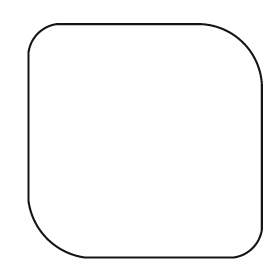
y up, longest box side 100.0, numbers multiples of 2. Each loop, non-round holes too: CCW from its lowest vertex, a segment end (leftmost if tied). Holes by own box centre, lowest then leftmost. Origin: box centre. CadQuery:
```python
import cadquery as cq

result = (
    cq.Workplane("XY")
    .moveTo(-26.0, -50.0)
    .lineTo(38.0, -50.0)
    .threePointArc((46.0, -46.0), (50.0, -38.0))
    .lineTo(50.0, 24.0)
    .threePointArc((42.0, 42.0), (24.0, 50.0))
    .lineTo(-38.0, 50.0)
    .threePointArc((-46.0, 46.0), (-50.0, 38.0))
    .lineTo(-50.0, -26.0)
    .threePointArc((-42.0, -42.0), (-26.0, -50.0))
    .close()
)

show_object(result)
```